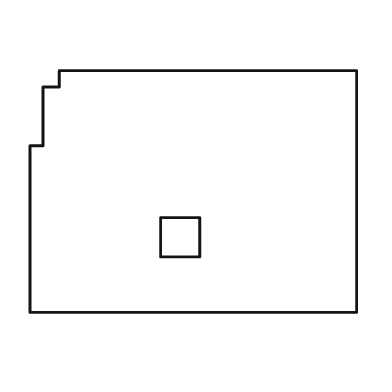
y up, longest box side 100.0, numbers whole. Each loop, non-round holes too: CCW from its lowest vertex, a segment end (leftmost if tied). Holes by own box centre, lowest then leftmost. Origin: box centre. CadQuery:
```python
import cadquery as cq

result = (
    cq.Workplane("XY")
    .moveTo(-50.0, -37.0)
    .lineTo(50.0, -37.0)
    .lineTo(50.0, 37.0)
    .lineTo(-41.0, 37.0)
    .lineTo(-41.0, 32.0)
    .lineTo(-46.0, 32.0)
    .lineTo(-46.0, 14.0)
    .lineTo(-50.0, 14.0)
    .close()
    .moveTo(-10.0, -20.0)
    .lineTo(2.0, -20.0)
    .lineTo(2.0, -8.0)
    .lineTo(-10.0, -8.0)
    .close()
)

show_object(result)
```